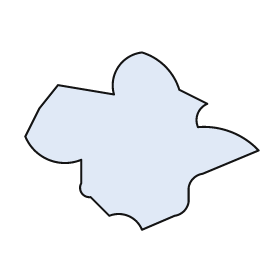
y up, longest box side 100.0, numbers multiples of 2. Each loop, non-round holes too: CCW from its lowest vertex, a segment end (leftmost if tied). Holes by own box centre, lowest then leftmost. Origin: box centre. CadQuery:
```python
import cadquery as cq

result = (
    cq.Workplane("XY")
    .moveTo(0.0, -38.0)
    .lineTo(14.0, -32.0)
    .threePointArc((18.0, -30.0), (20.0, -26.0))
    .lineTo(20.0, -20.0)
    .threePointArc((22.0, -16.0), (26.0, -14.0))
    .lineTo(50.0, -4.0)
    .threePointArc((38.0, 4.0), (24.0, 6.0))
    .threePointArc((24.0, 12.0), (28.0, 16.0))
    .lineTo(16.0, 22.0)
    .threePointArc((10.0, 32.0), (0.0, 38.0))
    .threePointArc((-10.0, 32.0), (-12.0, 20.0))
    .lineTo(-36.0, 24.0)
    .lineTo(-44.0, 14.0)
    .lineTo(-50.0, 2.0)
    .threePointArc((-40.0, -8.0), (-26.0, -8.0))
    .lineTo(-26.0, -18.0)
    .threePointArc((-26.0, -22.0), (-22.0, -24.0))
    .lineTo(-14.0, -32.0)
    .threePointArc((-6.0, -32.0), (0.0, -38.0))
    .close()
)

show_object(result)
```